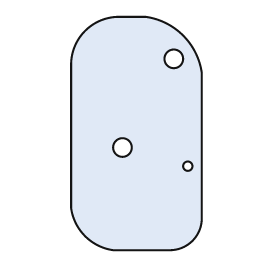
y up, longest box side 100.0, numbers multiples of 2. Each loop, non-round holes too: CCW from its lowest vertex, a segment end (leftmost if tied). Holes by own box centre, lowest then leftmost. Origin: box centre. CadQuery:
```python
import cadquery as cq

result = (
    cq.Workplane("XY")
    .moveTo(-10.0, -50.0)
    .lineTo(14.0, -50.0)
    .threePointArc((24.0, -46.0), (28.0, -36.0))
    .lineTo(28.0, 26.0)
    .threePointArc((20.0, 42.0), (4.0, 50.0))
    .lineTo(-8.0, 50.0)
    .threePointArc((-22.0, 44.0), (-28.0, 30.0))
    .lineTo(-28.0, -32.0)
    .threePointArc((-22.0, -44.0), (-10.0, -50.0))
    .close()
    .moveTo(22.0, -14.0)
    .circle(2.0)
    .moveTo(-6.0, -6.0)
    .circle(4.0)
    .moveTo(16.0, 32.0)
    .circle(4.0)
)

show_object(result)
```